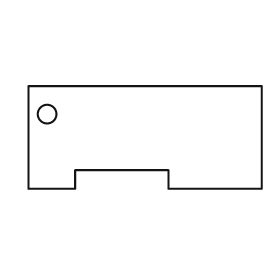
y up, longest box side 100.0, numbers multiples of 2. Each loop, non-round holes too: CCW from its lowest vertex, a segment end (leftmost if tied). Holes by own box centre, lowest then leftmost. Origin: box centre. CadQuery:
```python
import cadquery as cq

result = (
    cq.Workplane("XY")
    .moveTo(-50.0, -22.0)
    .lineTo(-30.0, -22.0)
    .lineTo(-30.0, -14.0)
    .lineTo(10.0, -14.0)
    .lineTo(10.0, -22.0)
    .lineTo(50.0, -22.0)
    .lineTo(50.0, 22.0)
    .lineTo(-50.0, 22.0)
    .close()
    .moveTo(-42.0, 10.0)
    .circle(4.0)
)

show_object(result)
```